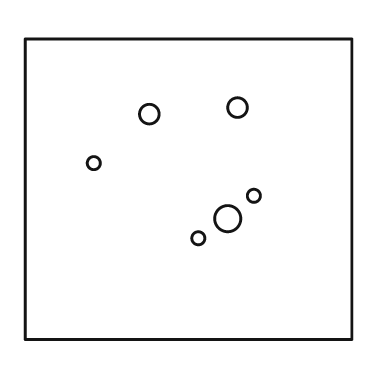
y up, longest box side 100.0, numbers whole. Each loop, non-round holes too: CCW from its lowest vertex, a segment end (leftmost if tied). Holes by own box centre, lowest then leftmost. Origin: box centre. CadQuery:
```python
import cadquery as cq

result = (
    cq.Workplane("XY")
    .moveTo(-50.0, -46.0)
    .lineTo(50.0, -46.0)
    .lineTo(50.0, 46.0)
    .lineTo(-50.0, 46.0)
    .close()
    .moveTo(3.0, -15.0)
    .circle(2.0)
    .moveTo(12.0, -9.0)
    .circle(4.0)
    .moveTo(20.0, -2.0)
    .circle(2.0)
    .moveTo(-29.0, 8.0)
    .circle(2.0)
    .moveTo(-12.0, 23.0)
    .circle(3.0)
    .moveTo(15.0, 25.0)
    .circle(3.0)
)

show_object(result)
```